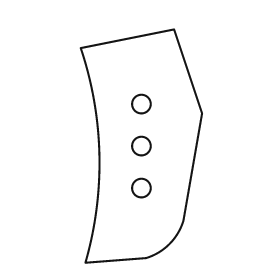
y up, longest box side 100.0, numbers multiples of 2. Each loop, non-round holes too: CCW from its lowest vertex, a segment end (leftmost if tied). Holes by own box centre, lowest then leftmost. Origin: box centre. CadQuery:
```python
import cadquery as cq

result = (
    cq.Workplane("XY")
    .moveTo(-24.0, -50.0)
    .lineTo(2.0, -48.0)
    .threePointArc((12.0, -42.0), (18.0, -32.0))
    .lineTo(26.0, 14.0)
    .lineTo(14.0, 50.0)
    .lineTo(-26.0, 42.0)
    .threePointArc((-18.0, -4.0), (-24.0, -50.0))
    .close()
    .moveTo(0.0, -18.0)
    .circle(4.0)
    .moveTo(0.0, 0.0)
    .circle(4.0)
    .moveTo(0.0, 18.0)
    .circle(4.0)
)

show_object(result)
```